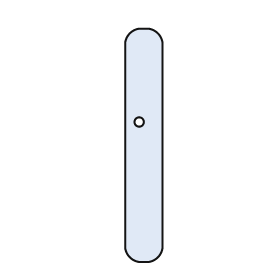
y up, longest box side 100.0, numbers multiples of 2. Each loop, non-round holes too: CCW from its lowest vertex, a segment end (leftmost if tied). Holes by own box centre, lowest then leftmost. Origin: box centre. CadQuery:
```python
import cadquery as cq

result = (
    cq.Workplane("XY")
    .moveTo(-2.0, -50.0)
    .lineTo(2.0, -50.0)
    .threePointArc((6.0, -48.0), (8.0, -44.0))
    .lineTo(8.0, 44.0)
    .threePointArc((6.0, 48.0), (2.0, 50.0))
    .lineTo(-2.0, 50.0)
    .threePointArc((-6.0, 48.0), (-8.0, 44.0))
    .lineTo(-8.0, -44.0)
    .threePointArc((-6.0, -48.0), (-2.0, -50.0))
    .close()
    .moveTo(-2.0, 10.0)
    .circle(2.0)
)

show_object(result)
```